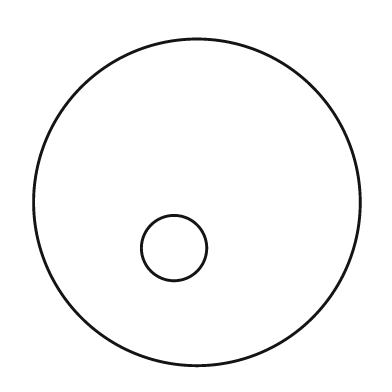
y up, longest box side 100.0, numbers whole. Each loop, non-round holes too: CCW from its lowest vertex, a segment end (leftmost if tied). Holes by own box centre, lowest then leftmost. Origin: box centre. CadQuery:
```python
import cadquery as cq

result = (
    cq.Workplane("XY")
    .moveTo(0.0, 0.0)
    .circle(50.0)
    .moveTo(-7.0, -14.0)
    .circle(10.0)
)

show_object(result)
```